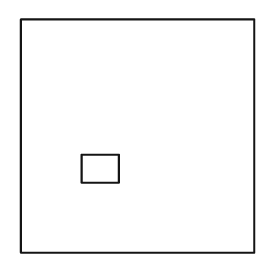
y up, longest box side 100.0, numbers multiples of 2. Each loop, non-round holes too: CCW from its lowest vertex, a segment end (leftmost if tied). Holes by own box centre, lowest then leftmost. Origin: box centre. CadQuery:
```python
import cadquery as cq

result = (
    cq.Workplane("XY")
    .moveTo(-50.0, -50.0)
    .lineTo(50.0, -50.0)
    .lineTo(50.0, 50.0)
    .lineTo(-50.0, 50.0)
    .close()
    .moveTo(-24.0, -20.0)
    .lineTo(-8.0, -20.0)
    .lineTo(-8.0, -8.0)
    .lineTo(-24.0, -8.0)
    .close()
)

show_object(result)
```